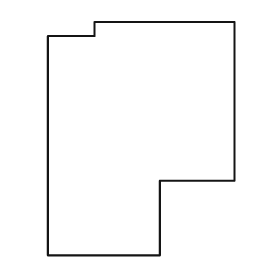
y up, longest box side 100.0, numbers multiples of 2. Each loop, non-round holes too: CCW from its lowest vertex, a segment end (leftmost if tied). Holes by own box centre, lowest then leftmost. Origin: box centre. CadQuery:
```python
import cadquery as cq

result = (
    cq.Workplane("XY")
    .moveTo(-40.0, -50.0)
    .lineTo(8.0, -50.0)
    .lineTo(8.0, -18.0)
    .lineTo(40.0, -18.0)
    .lineTo(40.0, 50.0)
    .lineTo(-20.0, 50.0)
    .lineTo(-20.0, 44.0)
    .lineTo(-40.0, 44.0)
    .close()
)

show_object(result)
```